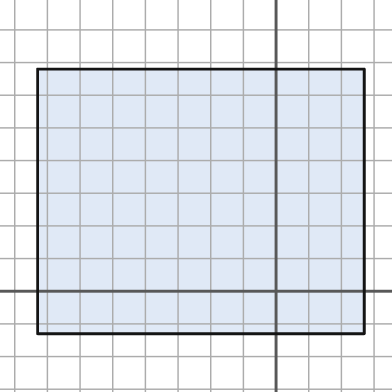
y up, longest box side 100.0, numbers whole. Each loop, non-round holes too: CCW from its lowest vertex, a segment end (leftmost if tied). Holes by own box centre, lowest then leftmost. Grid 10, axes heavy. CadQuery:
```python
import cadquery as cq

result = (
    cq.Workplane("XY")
    .moveTo(-73.0, -13.0)
    .lineTo(27.0, -13.0)
    .lineTo(27.0, 68.0)
    .lineTo(-73.0, 68.0)
    .close()
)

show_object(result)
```